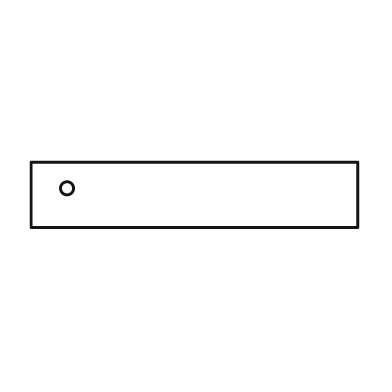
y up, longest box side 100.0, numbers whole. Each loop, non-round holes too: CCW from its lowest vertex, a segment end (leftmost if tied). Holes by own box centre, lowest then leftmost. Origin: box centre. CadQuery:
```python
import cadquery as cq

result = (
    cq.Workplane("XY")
    .moveTo(-50.0, -10.0)
    .lineTo(50.0, -10.0)
    .lineTo(50.0, 10.0)
    .lineTo(-50.0, 10.0)
    .close()
    .moveTo(-39.0, 2.0)
    .circle(2.0)
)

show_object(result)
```